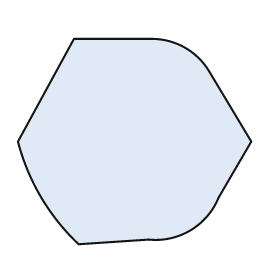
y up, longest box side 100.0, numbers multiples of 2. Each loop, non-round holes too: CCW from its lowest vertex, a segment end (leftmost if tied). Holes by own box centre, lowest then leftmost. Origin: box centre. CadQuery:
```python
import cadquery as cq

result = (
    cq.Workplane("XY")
    .moveTo(-24.0, -44.0)
    .lineTo(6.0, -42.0)
    .threePointArc((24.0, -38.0), (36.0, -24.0))
    .lineTo(50.0, 0.0)
    .lineTo(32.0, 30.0)
    .threePointArc((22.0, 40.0), (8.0, 44.0))
    .lineTo(-26.0, 44.0)
    .lineTo(-50.0, 0.0)
    .threePointArc((-40.0, -24.0), (-24.0, -44.0))
    .close()
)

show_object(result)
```